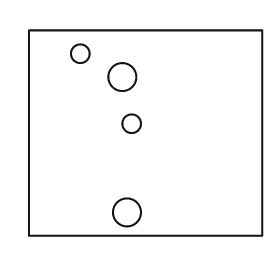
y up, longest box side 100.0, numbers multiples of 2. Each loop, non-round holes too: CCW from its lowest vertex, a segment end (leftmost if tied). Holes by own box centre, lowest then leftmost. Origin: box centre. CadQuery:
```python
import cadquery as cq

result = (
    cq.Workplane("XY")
    .moveTo(-50.0, -44.0)
    .lineTo(50.0, -44.0)
    .lineTo(50.0, 44.0)
    .lineTo(-50.0, 44.0)
    .close()
    .moveTo(-8.0, -34.0)
    .circle(6.0)
    .moveTo(-6.0, 4.0)
    .circle(4.0)
    .moveTo(-10.0, 24.0)
    .circle(6.0)
    .moveTo(-28.0, 34.0)
    .circle(4.0)
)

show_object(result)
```